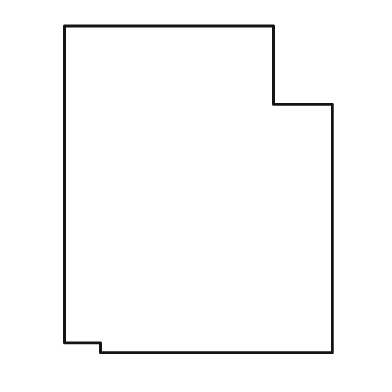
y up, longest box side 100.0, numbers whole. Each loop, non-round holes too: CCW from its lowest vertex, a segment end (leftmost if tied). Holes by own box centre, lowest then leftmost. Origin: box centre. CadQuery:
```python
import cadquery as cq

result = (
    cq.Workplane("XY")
    .moveTo(-30.0, -50.0)
    .lineTo(41.0, -50.0)
    .lineTo(41.0, 26.0)
    .lineTo(23.0, 26.0)
    .lineTo(23.0, 50.0)
    .lineTo(-41.0, 50.0)
    .lineTo(-41.0, -47.0)
    .lineTo(-30.0, -47.0)
    .close()
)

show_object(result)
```